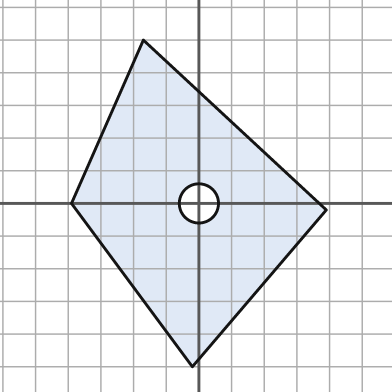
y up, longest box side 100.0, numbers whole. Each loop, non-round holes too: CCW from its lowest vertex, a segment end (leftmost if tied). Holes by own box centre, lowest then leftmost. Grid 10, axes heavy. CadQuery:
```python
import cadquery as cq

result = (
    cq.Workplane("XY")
    .moveTo(-2.0, -50.0)
    .lineTo(39.0, -2.0)
    .lineTo(-17.0, 50.0)
    .lineTo(-39.0, 0.0)
    .close()
    .moveTo(0.0, 0.0)
    .circle(6.0)
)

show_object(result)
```